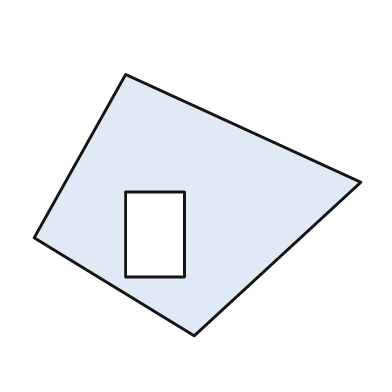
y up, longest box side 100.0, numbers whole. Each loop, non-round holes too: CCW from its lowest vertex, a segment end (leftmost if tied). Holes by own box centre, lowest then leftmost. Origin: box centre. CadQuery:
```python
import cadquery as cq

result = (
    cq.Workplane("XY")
    .moveTo(-1.0, -40.0)
    .lineTo(50.0, 7.0)
    .lineTo(-22.0, 40.0)
    .lineTo(-50.0, -10.0)
    .close()
    .moveTo(-22.0, -22.0)
    .lineTo(-4.0, -22.0)
    .lineTo(-4.0, 4.0)
    .lineTo(-22.0, 4.0)
    .close()
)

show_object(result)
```